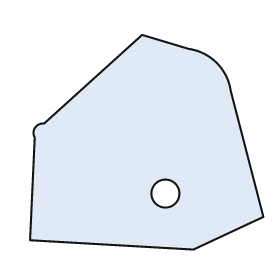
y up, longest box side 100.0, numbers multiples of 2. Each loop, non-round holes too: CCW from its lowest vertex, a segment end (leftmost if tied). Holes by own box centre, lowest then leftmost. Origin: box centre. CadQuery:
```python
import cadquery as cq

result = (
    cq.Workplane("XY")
    .moveTo(20.0, -46.0)
    .lineTo(50.0, -32.0)
    .lineTo(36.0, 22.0)
    .threePointArc((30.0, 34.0), (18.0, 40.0))
    .lineTo(-2.0, 46.0)
    .lineTo(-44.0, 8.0)
    .threePointArc((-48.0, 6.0), (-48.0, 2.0))
    .lineTo(-50.0, -42.0)
    .close()
    .moveTo(8.0, -22.0)
    .circle(6.0)
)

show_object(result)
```